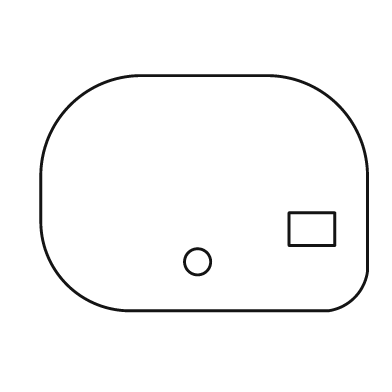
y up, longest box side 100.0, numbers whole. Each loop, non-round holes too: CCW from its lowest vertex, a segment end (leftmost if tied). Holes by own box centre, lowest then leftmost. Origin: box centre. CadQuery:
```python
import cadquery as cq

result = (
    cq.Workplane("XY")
    .moveTo(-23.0, -36.0)
    .lineTo(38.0, -36.0)
    .threePointArc((46.0, -32.0), (50.0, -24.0))
    .lineTo(50.0, 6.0)
    .threePointArc((41.0, 27.0), (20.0, 36.0))
    .lineTo(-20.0, 36.0)
    .threePointArc((-41.0, 27.0), (-50.0, 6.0))
    .lineTo(-50.0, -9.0)
    .threePointArc((-42.0, -28.0), (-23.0, -36.0))
    .close()
    .moveTo(-2.0, -21.0)
    .circle(4.0)
    .moveTo(26.0, -16.0)
    .lineTo(40.0, -16.0)
    .lineTo(40.0, -6.0)
    .lineTo(26.0, -6.0)
    .close()
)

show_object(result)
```